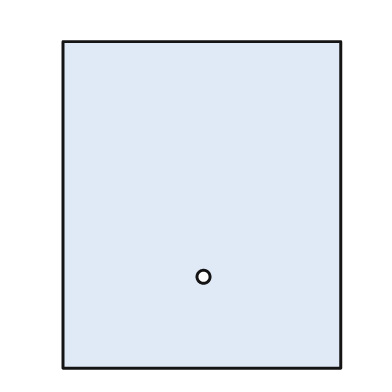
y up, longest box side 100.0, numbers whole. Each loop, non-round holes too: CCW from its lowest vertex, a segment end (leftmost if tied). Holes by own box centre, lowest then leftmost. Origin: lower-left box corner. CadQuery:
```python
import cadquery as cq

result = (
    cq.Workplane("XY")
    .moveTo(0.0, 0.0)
    .lineTo(85.0, 0.0)
    .lineTo(85.0, 100.0)
    .lineTo(0.0, 100.0)
    .close()
    .moveTo(43.0, 28.0)
    .circle(2.0)
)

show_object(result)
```